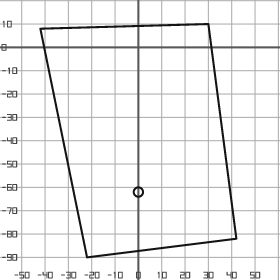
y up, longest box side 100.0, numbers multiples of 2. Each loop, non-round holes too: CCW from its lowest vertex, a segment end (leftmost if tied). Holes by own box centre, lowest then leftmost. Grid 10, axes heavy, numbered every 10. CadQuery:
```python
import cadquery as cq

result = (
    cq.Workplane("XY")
    .moveTo(-22.0, -90.0)
    .lineTo(42.0, -82.0)
    .lineTo(30.0, 10.0)
    .lineTo(-42.0, 8.0)
    .close()
    .moveTo(0.0, -62.0)
    .circle(2.0)
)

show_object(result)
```